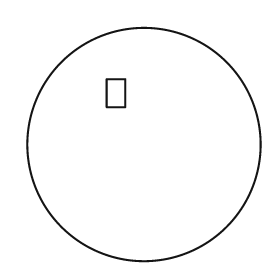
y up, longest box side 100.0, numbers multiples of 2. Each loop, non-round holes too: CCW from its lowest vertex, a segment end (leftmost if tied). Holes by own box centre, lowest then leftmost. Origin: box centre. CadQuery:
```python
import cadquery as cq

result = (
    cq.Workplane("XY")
    .moveTo(0.0, 0.0)
    .circle(50.0)
    .moveTo(-16.0, 16.0)
    .lineTo(-8.0, 16.0)
    .lineTo(-8.0, 28.0)
    .lineTo(-16.0, 28.0)
    .close()
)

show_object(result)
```